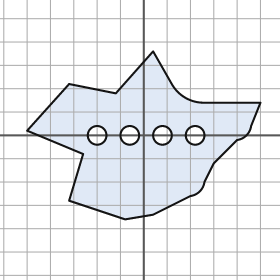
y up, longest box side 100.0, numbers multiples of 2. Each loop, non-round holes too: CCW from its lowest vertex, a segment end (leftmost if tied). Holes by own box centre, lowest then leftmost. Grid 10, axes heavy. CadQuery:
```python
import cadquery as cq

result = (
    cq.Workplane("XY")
    .moveTo(-8.0, -36.0)
    .lineTo(4.0, -34.0)
    .lineTo(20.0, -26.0)
    .threePointArc((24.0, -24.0), (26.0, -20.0))
    .lineTo(30.0, -12.0)
    .lineTo(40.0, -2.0)
    .threePointArc((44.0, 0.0), (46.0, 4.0))
    .lineTo(50.0, 14.0)
    .lineTo(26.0, 14.0)
    .threePointArc((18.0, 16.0), (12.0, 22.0))
    .lineTo(4.0, 36.0)
    .lineTo(-12.0, 18.0)
    .lineTo(-32.0, 22.0)
    .lineTo(-50.0, 2.0)
    .lineTo(-26.0, -8.0)
    .lineTo(-32.0, -28.0)
    .close()
    .moveTo(-20.0, 0.0)
    .circle(4.0)
    .moveTo(-6.0, 0.0)
    .circle(4.0)
    .moveTo(8.0, 0.0)
    .circle(4.0)
    .moveTo(22.0, 0.0)
    .circle(4.0)
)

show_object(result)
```